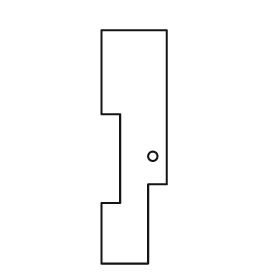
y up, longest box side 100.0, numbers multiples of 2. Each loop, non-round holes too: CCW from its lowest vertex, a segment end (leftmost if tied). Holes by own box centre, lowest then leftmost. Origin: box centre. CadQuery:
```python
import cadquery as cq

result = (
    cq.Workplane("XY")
    .moveTo(-14.0, -50.0)
    .lineTo(6.0, -50.0)
    .lineTo(6.0, -16.0)
    .lineTo(14.0, -16.0)
    .lineTo(14.0, 50.0)
    .lineTo(-14.0, 50.0)
    .lineTo(-14.0, 14.0)
    .lineTo(-6.0, 14.0)
    .lineTo(-6.0, -24.0)
    .lineTo(-14.0, -24.0)
    .close()
    .moveTo(8.0, -4.0)
    .circle(2.0)
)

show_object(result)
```